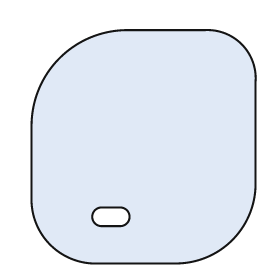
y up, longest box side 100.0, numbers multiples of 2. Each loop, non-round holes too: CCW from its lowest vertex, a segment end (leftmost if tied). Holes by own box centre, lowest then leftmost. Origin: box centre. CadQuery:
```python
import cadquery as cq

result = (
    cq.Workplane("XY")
    .moveTo(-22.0, -50.0)
    .lineTo(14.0, -50.0)
    .threePointArc((38.0, -40.0), (48.0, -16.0))
    .lineTo(48.0, 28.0)
    .threePointArc((42.0, 44.0), (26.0, 50.0))
    .lineTo(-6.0, 50.0)
    .threePointArc((-36.0, 38.0), (-48.0, 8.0))
    .lineTo(-48.0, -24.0)
    .threePointArc((-40.0, -42.0), (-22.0, -50.0))
    .close()
    .moveTo(-18.0, -34.0)
    .lineTo(-10.0, -34.0)
    .threePointArc((-6.0, -30.0), (-10.0, -26.0))
    .lineTo(-18.0, -26.0)
    .threePointArc((-22.0, -30.0), (-18.0, -34.0))
    .close()
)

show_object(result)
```